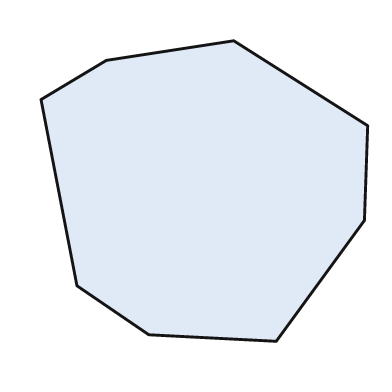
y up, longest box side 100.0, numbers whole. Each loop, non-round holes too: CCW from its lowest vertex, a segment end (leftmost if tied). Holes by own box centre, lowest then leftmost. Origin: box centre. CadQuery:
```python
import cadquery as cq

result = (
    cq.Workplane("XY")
    .moveTo(22.0, -46.0)
    .lineTo(49.0, -9.0)
    .lineTo(50.0, 20.0)
    .lineTo(9.0, 46.0)
    .lineTo(-30.0, 40.0)
    .lineTo(-50.0, 28.0)
    .lineTo(-39.0, -29.0)
    .lineTo(-17.0, -44.0)
    .close()
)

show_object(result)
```